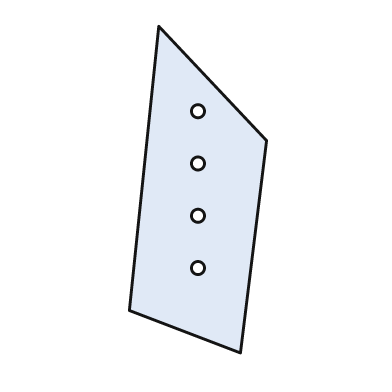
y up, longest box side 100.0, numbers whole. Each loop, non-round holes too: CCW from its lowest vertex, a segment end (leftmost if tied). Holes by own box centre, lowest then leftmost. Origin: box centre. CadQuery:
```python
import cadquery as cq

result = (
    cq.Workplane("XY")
    .moveTo(13.0, -50.0)
    .lineTo(21.0, 15.0)
    .lineTo(-12.0, 50.0)
    .lineTo(-21.0, -37.0)
    .close()
    .moveTo(0.0, -24.0)
    .circle(2.0)
    .moveTo(0.0, -8.0)
    .circle(2.0)
    .moveTo(0.0, 8.0)
    .circle(2.0)
    .moveTo(0.0, 24.0)
    .circle(2.0)
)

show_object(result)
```